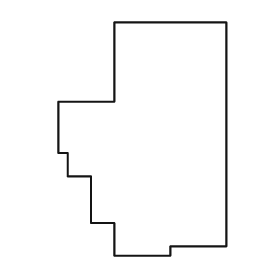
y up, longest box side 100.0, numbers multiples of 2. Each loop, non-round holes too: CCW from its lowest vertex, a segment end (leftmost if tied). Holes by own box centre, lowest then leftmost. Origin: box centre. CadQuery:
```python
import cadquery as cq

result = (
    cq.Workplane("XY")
    .moveTo(-12.0, -50.0)
    .lineTo(12.0, -50.0)
    .lineTo(12.0, -46.0)
    .lineTo(36.0, -46.0)
    .lineTo(36.0, 50.0)
    .lineTo(-12.0, 50.0)
    .lineTo(-12.0, 16.0)
    .lineTo(-36.0, 16.0)
    .lineTo(-36.0, -6.0)
    .lineTo(-32.0, -6.0)
    .lineTo(-32.0, -16.0)
    .lineTo(-22.0, -16.0)
    .lineTo(-22.0, -36.0)
    .lineTo(-12.0, -36.0)
    .close()
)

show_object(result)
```